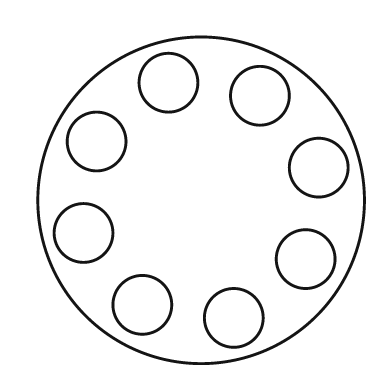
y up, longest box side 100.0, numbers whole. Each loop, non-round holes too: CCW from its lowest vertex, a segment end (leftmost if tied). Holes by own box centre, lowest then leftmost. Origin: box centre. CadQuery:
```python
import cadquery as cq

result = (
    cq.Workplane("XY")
    .moveTo(0.0, 0.0)
    .circle(50.0)
    .moveTo(10.0, -36.0)
    .circle(9.0)
    .moveTo(-18.0, -32.0)
    .circle(9.0)
    .moveTo(32.0, -18.0)
    .circle(9.0)
    .moveTo(-36.0, -10.0)
    .circle(9.0)
    .moveTo(36.0, 10.0)
    .circle(9.0)
    .moveTo(-32.0, 18.0)
    .circle(9.0)
    .moveTo(18.0, 32.0)
    .circle(9.0)
    .moveTo(-10.0, 36.0)
    .circle(9.0)
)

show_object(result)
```